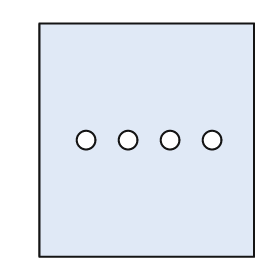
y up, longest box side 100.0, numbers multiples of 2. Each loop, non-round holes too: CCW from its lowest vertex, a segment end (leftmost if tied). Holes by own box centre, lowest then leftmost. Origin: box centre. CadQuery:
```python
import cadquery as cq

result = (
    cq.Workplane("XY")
    .moveTo(-46.0, -50.0)
    .lineTo(46.0, -50.0)
    .lineTo(46.0, 50.0)
    .lineTo(-46.0, 50.0)
    .close()
    .moveTo(-26.0, 0.0)
    .circle(4.0)
    .moveTo(-8.0, 0.0)
    .circle(4.0)
    .moveTo(10.0, 0.0)
    .circle(4.0)
    .moveTo(28.0, 0.0)
    .circle(4.0)
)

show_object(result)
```